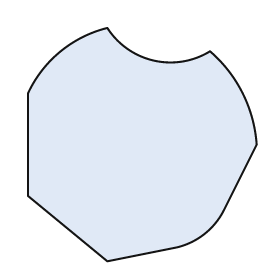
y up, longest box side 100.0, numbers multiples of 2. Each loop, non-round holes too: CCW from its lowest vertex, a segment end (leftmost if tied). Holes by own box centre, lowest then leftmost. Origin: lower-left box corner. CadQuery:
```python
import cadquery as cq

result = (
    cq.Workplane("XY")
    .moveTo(34.0, 0.0)
    .lineTo(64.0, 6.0)
    .threePointArc((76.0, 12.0), (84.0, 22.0))
    .lineTo(98.0, 50.0)
    .threePointArc((92.0, 72.0), (78.0, 90.0))
    .threePointArc((54.0, 86.0), (34.0, 100.0))
    .threePointArc((14.0, 90.0), (0.0, 72.0))
    .lineTo(0.0, 28.0)
    .close()
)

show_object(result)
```